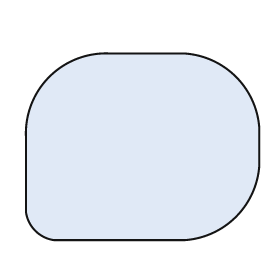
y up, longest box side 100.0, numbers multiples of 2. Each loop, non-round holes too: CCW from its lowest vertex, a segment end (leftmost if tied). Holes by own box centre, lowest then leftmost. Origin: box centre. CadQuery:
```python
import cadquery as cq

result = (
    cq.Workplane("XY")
    .moveTo(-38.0, -40.0)
    .lineTo(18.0, -40.0)
    .threePointArc((40.0, -30.0), (50.0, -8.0))
    .lineTo(50.0, 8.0)
    .threePointArc((40.0, 30.0), (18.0, 40.0))
    .lineTo(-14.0, 40.0)
    .threePointArc((-40.0, 30.0), (-50.0, 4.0))
    .lineTo(-50.0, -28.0)
    .threePointArc((-46.0, -36.0), (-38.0, -40.0))
    .close()
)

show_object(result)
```